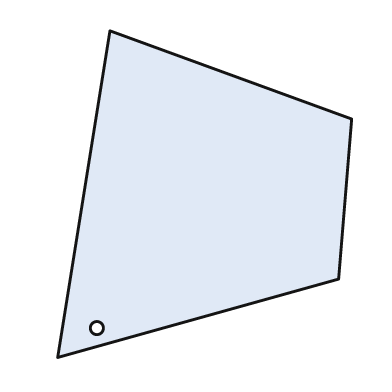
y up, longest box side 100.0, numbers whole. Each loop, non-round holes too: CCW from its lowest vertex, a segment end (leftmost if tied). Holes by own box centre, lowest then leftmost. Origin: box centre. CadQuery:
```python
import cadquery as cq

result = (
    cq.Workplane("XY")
    .moveTo(-45.0, -50.0)
    .lineTo(41.0, -26.0)
    .lineTo(45.0, 23.0)
    .lineTo(-29.0, 50.0)
    .close()
    .moveTo(-33.0, -41.0)
    .circle(2.0)
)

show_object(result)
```